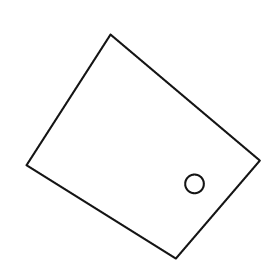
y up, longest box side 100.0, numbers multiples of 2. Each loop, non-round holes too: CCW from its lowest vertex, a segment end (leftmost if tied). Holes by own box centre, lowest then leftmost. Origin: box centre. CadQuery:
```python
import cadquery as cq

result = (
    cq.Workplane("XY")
    .moveTo(14.0, -48.0)
    .lineTo(50.0, -6.0)
    .lineTo(-14.0, 48.0)
    .lineTo(-50.0, -8.0)
    .close()
    .moveTo(22.0, -16.0)
    .circle(4.0)
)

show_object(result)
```